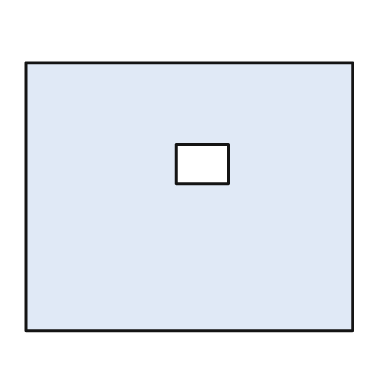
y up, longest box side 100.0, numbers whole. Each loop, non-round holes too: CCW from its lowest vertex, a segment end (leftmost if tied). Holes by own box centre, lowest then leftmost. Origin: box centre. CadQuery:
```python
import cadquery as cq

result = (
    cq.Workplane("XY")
    .moveTo(-50.0, -41.0)
    .lineTo(50.0, -41.0)
    .lineTo(50.0, 41.0)
    .lineTo(-50.0, 41.0)
    .close()
    .moveTo(-4.0, 4.0)
    .lineTo(12.0, 4.0)
    .lineTo(12.0, 16.0)
    .lineTo(-4.0, 16.0)
    .close()
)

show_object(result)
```